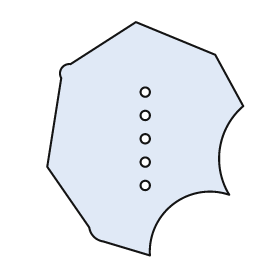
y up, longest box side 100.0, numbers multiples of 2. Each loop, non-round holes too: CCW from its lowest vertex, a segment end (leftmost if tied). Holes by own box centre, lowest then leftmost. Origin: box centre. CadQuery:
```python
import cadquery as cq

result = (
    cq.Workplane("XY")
    .moveTo(2.0, -50.0)
    .threePointArc((12.0, -28.0), (36.0, -24.0))
    .threePointArc((32.0, -4.0), (42.0, 14.0))
    .lineTo(30.0, 36.0)
    .lineTo(-4.0, 50.0)
    .lineTo(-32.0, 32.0)
    .threePointArc((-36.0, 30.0), (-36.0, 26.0))
    .lineTo(-42.0, -12.0)
    .lineTo(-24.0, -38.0)
    .threePointArc((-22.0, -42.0), (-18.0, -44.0))
    .close()
    .moveTo(0.0, -20.0)
    .circle(2.0)
    .moveTo(0.0, -10.0)
    .circle(2.0)
    .moveTo(0.0, 0.0)
    .circle(2.0)
    .moveTo(0.0, 10.0)
    .circle(2.0)
    .moveTo(0.0, 20.0)
    .circle(2.0)
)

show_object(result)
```